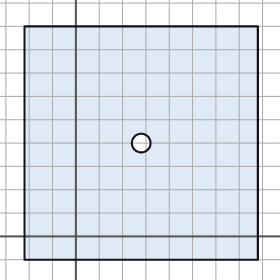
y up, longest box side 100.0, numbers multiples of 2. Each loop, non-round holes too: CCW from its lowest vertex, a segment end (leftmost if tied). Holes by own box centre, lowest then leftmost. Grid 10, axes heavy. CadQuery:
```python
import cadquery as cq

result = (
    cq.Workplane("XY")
    .moveTo(-22.0, -10.0)
    .lineTo(78.0, -10.0)
    .lineTo(78.0, 90.0)
    .lineTo(-22.0, 90.0)
    .close()
    .moveTo(28.0, 40.0)
    .circle(4.0)
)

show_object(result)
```